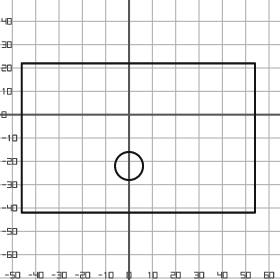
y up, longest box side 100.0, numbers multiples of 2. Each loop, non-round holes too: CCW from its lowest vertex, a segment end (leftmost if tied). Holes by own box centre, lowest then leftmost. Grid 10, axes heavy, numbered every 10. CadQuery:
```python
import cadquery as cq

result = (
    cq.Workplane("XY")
    .moveTo(-46.0, -42.0)
    .lineTo(54.0, -42.0)
    .lineTo(54.0, 22.0)
    .lineTo(-46.0, 22.0)
    .close()
    .moveTo(0.0, -22.0)
    .circle(6.0)
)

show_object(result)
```